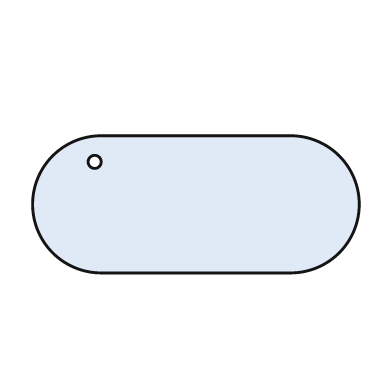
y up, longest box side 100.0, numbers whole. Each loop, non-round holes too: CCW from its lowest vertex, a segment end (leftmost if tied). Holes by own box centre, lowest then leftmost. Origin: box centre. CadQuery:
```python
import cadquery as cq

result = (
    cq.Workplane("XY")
    .moveTo(-29.0, -21.0)
    .lineTo(29.0, -21.0)
    .threePointArc((50.0, 0.0), (29.0, 21.0))
    .lineTo(-29.0, 21.0)
    .threePointArc((-50.0, 0.0), (-29.0, -21.0))
    .close()
    .moveTo(-31.0, 13.0)
    .circle(2.0)
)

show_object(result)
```